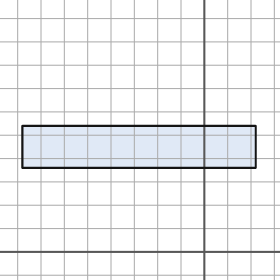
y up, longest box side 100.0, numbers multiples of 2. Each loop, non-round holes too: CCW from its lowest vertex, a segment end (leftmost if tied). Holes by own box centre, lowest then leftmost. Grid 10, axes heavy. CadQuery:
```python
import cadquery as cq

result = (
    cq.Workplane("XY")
    .moveTo(-78.0, 36.0)
    .lineTo(22.0, 36.0)
    .lineTo(22.0, 54.0)
    .lineTo(-78.0, 54.0)
    .close()
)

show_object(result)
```